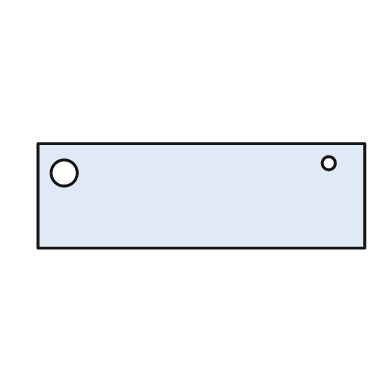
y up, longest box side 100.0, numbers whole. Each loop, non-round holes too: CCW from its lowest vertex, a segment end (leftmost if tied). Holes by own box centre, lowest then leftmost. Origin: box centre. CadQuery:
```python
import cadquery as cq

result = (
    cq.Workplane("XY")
    .moveTo(-50.0, -16.0)
    .lineTo(50.0, -16.0)
    .lineTo(50.0, 16.0)
    .lineTo(-50.0, 16.0)
    .close()
    .moveTo(-42.0, 7.0)
    .circle(4.0)
    .moveTo(39.0, 10.0)
    .circle(2.0)
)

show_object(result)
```